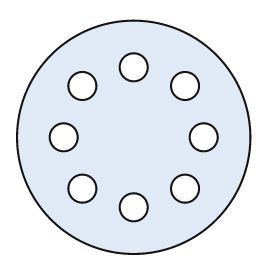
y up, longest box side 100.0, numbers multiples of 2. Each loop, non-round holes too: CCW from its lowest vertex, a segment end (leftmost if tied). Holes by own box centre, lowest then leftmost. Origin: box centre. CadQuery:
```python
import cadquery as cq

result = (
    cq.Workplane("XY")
    .moveTo(0.0, 0.0)
    .circle(50.0)
    .moveTo(0.0, -30.0)
    .circle(6.0)
    .moveTo(-22.0, -22.0)
    .circle(6.0)
    .moveTo(22.0, -22.0)
    .circle(6.0)
    .moveTo(-30.0, 0.0)
    .circle(6.0)
    .moveTo(30.0, 0.0)
    .circle(6.0)
    .moveTo(-22.0, 22.0)
    .circle(6.0)
    .moveTo(22.0, 22.0)
    .circle(6.0)
    .moveTo(0.0, 30.0)
    .circle(6.0)
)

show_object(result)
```